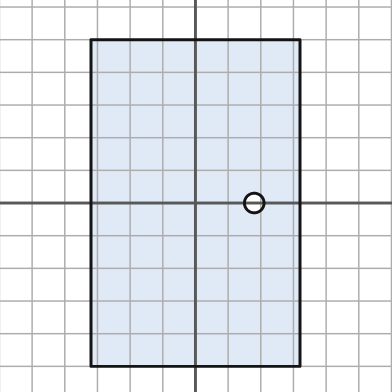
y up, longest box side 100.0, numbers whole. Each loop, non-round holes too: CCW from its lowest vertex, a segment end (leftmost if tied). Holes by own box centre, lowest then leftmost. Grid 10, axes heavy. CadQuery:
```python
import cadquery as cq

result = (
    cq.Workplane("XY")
    .moveTo(-32.0, -50.0)
    .lineTo(32.0, -50.0)
    .lineTo(32.0, 50.0)
    .lineTo(-32.0, 50.0)
    .close()
    .moveTo(18.0, 0.0)
    .circle(3.0)
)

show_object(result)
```